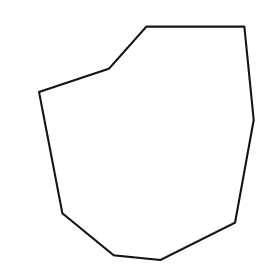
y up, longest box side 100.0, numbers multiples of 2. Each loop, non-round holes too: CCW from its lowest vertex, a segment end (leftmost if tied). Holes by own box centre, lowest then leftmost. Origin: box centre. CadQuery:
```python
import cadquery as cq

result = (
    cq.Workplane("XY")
    .moveTo(6.0, -50.0)
    .lineTo(38.0, -34.0)
    .lineTo(46.0, 10.0)
    .lineTo(42.0, 50.0)
    .lineTo(0.0, 50.0)
    .lineTo(-16.0, 32.0)
    .lineTo(-46.0, 22.0)
    .lineTo(-36.0, -30.0)
    .lineTo(-14.0, -48.0)
    .close()
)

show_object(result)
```